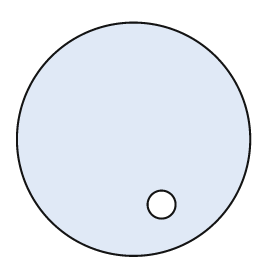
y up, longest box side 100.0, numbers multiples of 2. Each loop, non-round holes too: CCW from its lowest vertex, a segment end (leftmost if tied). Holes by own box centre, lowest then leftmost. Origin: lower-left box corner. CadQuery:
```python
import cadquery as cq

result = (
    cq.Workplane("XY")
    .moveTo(50.0, 50.0)
    .circle(50.0)
    .moveTo(62.0, 22.0)
    .circle(6.0)
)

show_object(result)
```